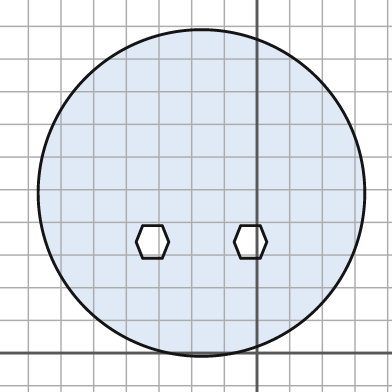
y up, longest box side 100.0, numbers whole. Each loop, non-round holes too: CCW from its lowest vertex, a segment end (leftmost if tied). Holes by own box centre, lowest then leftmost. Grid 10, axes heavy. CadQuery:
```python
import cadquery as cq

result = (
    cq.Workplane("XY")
    .moveTo(-17.0, 49.0)
    .circle(50.0)
    .moveTo(-35.0, 29.0)
    .lineTo(-29.0, 29.0)
    .lineTo(-27.0, 34.0)
    .lineTo(-29.0, 39.0)
    .lineTo(-35.0, 39.0)
    .lineTo(-37.0, 34.0)
    .close()
    .moveTo(-5.0, 29.0)
    .lineTo(1.0, 29.0)
    .lineTo(3.0, 34.0)
    .lineTo(1.0, 39.0)
    .lineTo(-5.0, 39.0)
    .lineTo(-7.0, 34.0)
    .close()
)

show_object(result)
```